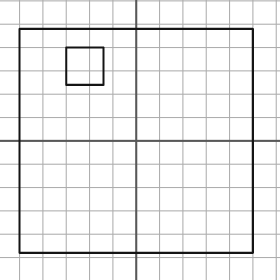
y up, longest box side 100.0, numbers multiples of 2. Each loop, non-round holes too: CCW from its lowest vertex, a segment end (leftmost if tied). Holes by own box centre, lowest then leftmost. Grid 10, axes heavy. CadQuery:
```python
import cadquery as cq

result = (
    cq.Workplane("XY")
    .moveTo(-50.0, -48.0)
    .lineTo(50.0, -48.0)
    .lineTo(50.0, 48.0)
    .lineTo(-50.0, 48.0)
    .close()
    .moveTo(-30.0, 24.0)
    .lineTo(-14.0, 24.0)
    .lineTo(-14.0, 40.0)
    .lineTo(-30.0, 40.0)
    .close()
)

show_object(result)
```